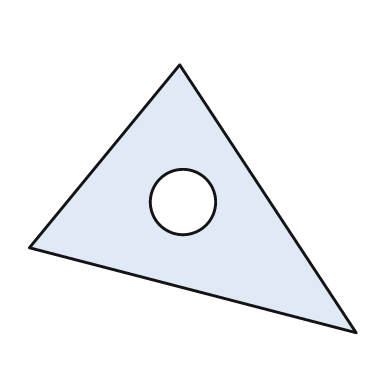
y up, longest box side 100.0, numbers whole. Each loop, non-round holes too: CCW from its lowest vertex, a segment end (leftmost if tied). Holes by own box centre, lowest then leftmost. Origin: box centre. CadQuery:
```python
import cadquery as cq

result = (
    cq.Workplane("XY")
    .moveTo(50.0, -41.0)
    .lineTo(-4.0, 41.0)
    .lineTo(-50.0, -15.0)
    .close()
    .moveTo(-3.0, -1.0)
    .circle(10.0)
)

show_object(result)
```